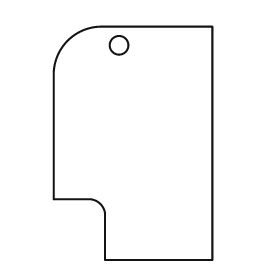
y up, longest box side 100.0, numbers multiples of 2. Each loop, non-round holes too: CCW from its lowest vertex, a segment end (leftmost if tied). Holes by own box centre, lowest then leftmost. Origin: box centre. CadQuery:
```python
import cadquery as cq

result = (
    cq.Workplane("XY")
    .moveTo(-12.0, -50.0)
    .lineTo(34.0, -50.0)
    .lineTo(34.0, 50.0)
    .lineTo(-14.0, 50.0)
    .threePointArc((-28.0, 44.0), (-34.0, 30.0))
    .lineTo(-34.0, -24.0)
    .lineTo(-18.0, -24.0)
    .threePointArc((-14.0, -26.0), (-12.0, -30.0))
    .close()
    .moveTo(-6.0, 42.0)
    .circle(4.0)
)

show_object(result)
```